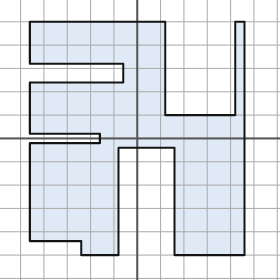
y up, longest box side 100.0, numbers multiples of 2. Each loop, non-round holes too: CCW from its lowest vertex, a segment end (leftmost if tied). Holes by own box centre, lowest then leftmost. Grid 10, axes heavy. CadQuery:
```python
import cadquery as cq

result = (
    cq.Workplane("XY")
    .moveTo(-24.0, -50.0)
    .lineTo(-8.0, -50.0)
    .lineTo(-8.0, -4.0)
    .lineTo(16.0, -4.0)
    .lineTo(16.0, -50.0)
    .lineTo(46.0, -50.0)
    .lineTo(46.0, 50.0)
    .lineTo(42.0, 50.0)
    .lineTo(42.0, 10.0)
    .lineTo(12.0, 10.0)
    .lineTo(12.0, 50.0)
    .lineTo(-46.0, 50.0)
    .lineTo(-46.0, 32.0)
    .lineTo(-6.0, 32.0)
    .lineTo(-6.0, 24.0)
    .lineTo(-46.0, 24.0)
    .lineTo(-46.0, 2.0)
    .lineTo(-16.0, 2.0)
    .lineTo(-16.0, -2.0)
    .lineTo(-46.0, -2.0)
    .lineTo(-46.0, -44.0)
    .lineTo(-24.0, -44.0)
    .close()
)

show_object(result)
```